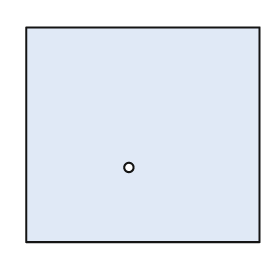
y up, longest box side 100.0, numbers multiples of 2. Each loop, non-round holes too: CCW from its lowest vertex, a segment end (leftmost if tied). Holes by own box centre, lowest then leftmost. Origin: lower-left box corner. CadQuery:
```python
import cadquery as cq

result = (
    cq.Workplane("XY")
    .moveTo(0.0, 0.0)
    .lineTo(100.0, 0.0)
    .lineTo(100.0, 92.0)
    .lineTo(0.0, 92.0)
    .close()
    .moveTo(44.0, 32.0)
    .circle(2.0)
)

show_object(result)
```